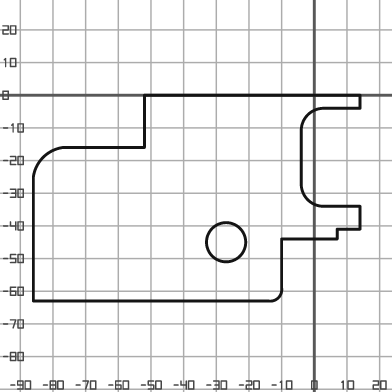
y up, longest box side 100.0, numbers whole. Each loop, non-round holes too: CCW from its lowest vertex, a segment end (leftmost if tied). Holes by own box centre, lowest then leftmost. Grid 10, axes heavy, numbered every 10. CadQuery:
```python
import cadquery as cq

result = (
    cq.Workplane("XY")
    .moveTo(-86.0, -63.0)
    .lineTo(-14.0, -63.0)
    .threePointArc((-11.0, -62.0), (-10.0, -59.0))
    .lineTo(-10.0, -44.0)
    .lineTo(7.0, -44.0)
    .lineTo(7.0, -41.0)
    .lineTo(14.0, -41.0)
    .lineTo(14.0, -34.0)
    .lineTo(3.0, -34.0)
    .threePointArc((-2.0, -32.0), (-4.0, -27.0))
    .lineTo(-4.0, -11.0)
    .threePointArc((-2.0, -6.0), (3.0, -4.0))
    .lineTo(14.0, -4.0)
    .lineTo(14.0, 0.0)
    .lineTo(-52.0, 0.0)
    .lineTo(-52.0, -16.0)
    .lineTo(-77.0, -16.0)
    .threePointArc((-83.0, -19.0), (-86.0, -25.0))
    .close()
    .moveTo(-27.0, -45.0)
    .circle(6.0)
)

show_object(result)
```